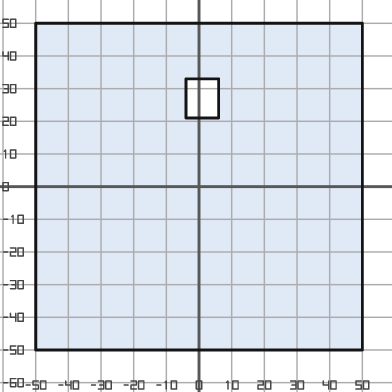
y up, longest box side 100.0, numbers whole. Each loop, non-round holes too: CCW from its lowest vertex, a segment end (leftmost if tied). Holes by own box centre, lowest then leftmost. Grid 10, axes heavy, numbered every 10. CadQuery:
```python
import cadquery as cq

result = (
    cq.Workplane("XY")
    .moveTo(-50.0, -50.0)
    .lineTo(50.0, -50.0)
    .lineTo(50.0, 50.0)
    .lineTo(-50.0, 50.0)
    .close()
    .moveTo(-4.0, 21.0)
    .lineTo(6.0, 21.0)
    .lineTo(6.0, 33.0)
    .lineTo(-4.0, 33.0)
    .close()
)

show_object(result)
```